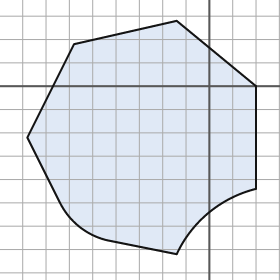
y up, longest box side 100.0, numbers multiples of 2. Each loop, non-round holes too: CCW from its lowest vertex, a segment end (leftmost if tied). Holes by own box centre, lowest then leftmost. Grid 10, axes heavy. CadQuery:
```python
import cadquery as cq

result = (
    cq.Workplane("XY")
    .moveTo(-14.0, -72.0)
    .threePointArc((0.0, -54.0), (20.0, -44.0))
    .lineTo(20.0, 0.0)
    .lineTo(-14.0, 28.0)
    .lineTo(-58.0, 18.0)
    .lineTo(-78.0, -22.0)
    .lineTo(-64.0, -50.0)
    .threePointArc((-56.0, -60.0), (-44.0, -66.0))
    .close()
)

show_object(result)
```